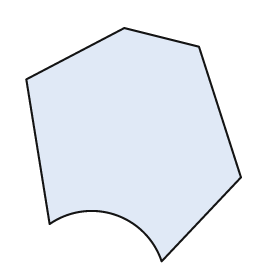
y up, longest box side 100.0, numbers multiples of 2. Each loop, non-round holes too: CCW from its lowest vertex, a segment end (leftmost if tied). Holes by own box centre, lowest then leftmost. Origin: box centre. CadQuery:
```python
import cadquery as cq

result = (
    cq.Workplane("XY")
    .moveTo(12.0, -50.0)
    .lineTo(46.0, -14.0)
    .lineTo(28.0, 42.0)
    .lineTo(-4.0, 50.0)
    .lineTo(-46.0, 28.0)
    .lineTo(-36.0, -34.0)
    .threePointArc((-8.0, -30.0), (12.0, -50.0))
    .close()
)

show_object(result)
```